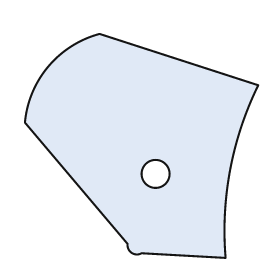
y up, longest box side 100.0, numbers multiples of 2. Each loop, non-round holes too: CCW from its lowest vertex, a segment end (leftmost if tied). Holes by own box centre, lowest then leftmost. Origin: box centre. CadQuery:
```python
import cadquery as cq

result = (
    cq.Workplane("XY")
    .moveTo(36.0, -48.0)
    .threePointArc((38.0, -10.0), (50.0, 26.0))
    .lineTo(-18.0, 48.0)
    .threePointArc((-40.0, 34.0), (-50.0, 10.0))
    .lineTo(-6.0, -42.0)
    .threePointArc((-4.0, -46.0), (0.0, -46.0))
    .close()
    .moveTo(6.0, -12.0)
    .circle(6.0)
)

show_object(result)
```